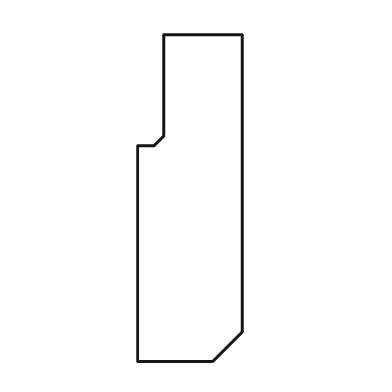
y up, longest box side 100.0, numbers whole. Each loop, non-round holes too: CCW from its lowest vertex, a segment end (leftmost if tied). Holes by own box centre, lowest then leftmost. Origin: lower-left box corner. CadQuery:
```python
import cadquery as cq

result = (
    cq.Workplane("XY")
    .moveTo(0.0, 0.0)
    .lineTo(23.0, 0.0)
    .lineTo(32.0, 9.0)
    .lineTo(32.0, 100.0)
    .lineTo(8.0, 100.0)
    .lineTo(8.0, 69.0)
    .lineTo(5.0, 66.0)
    .lineTo(0.0, 66.0)
    .close()
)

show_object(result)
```